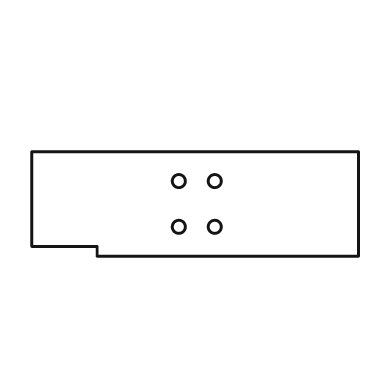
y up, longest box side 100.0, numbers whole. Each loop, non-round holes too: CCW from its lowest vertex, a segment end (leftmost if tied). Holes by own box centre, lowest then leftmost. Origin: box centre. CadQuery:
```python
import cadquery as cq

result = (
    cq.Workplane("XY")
    .moveTo(-30.0, -16.0)
    .lineTo(50.0, -16.0)
    .lineTo(50.0, 16.0)
    .lineTo(-50.0, 16.0)
    .lineTo(-50.0, -13.0)
    .lineTo(-30.0, -13.0)
    .close()
    .moveTo(-5.0, -7.0)
    .circle(2.0)
    .moveTo(6.0, -7.0)
    .circle(2.0)
    .moveTo(-5.0, 7.0)
    .circle(2.0)
    .moveTo(6.0, 7.0)
    .circle(2.0)
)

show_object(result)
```